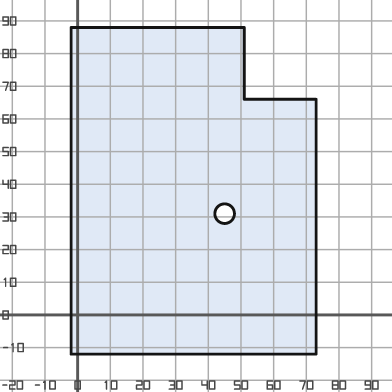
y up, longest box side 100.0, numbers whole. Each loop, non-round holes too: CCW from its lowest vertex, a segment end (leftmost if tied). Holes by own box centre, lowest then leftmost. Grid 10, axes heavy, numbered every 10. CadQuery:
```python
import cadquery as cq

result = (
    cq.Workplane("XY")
    .moveTo(-2.0, -12.0)
    .lineTo(73.0, -12.0)
    .lineTo(73.0, 66.0)
    .lineTo(51.0, 66.0)
    .lineTo(51.0, 88.0)
    .lineTo(-2.0, 88.0)
    .close()
    .moveTo(45.0, 31.0)
    .circle(3.0)
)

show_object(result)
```